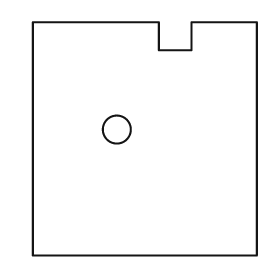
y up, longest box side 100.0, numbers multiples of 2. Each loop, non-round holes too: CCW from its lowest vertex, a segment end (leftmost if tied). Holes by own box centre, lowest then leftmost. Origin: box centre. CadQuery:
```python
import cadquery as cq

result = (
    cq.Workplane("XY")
    .moveTo(-48.0, -50.0)
    .lineTo(48.0, -50.0)
    .lineTo(48.0, 50.0)
    .lineTo(20.0, 50.0)
    .lineTo(20.0, 38.0)
    .lineTo(6.0, 38.0)
    .lineTo(6.0, 50.0)
    .lineTo(-48.0, 50.0)
    .close()
    .moveTo(-12.0, 4.0)
    .circle(6.0)
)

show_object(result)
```